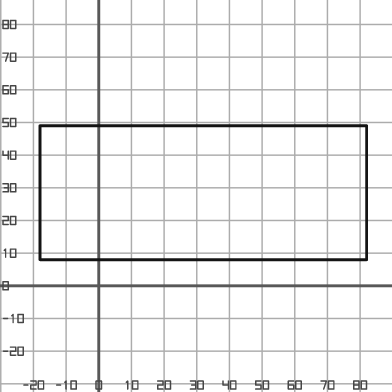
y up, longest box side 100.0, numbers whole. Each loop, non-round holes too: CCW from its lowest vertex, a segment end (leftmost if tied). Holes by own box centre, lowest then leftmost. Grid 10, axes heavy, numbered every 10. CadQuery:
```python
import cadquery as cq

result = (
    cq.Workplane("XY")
    .moveTo(-18.0, 8.0)
    .lineTo(82.0, 8.0)
    .lineTo(82.0, 49.0)
    .lineTo(-18.0, 49.0)
    .close()
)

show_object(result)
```